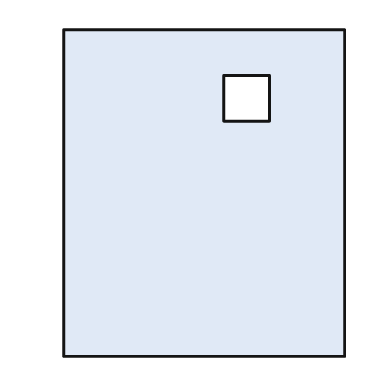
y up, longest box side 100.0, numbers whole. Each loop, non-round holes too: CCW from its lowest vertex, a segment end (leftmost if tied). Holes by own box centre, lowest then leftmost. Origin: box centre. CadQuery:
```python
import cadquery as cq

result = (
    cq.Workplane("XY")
    .moveTo(-43.0, -50.0)
    .lineTo(43.0, -50.0)
    .lineTo(43.0, 50.0)
    .lineTo(-43.0, 50.0)
    .close()
    .moveTo(6.0, 22.0)
    .lineTo(20.0, 22.0)
    .lineTo(20.0, 36.0)
    .lineTo(6.0, 36.0)
    .close()
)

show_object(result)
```